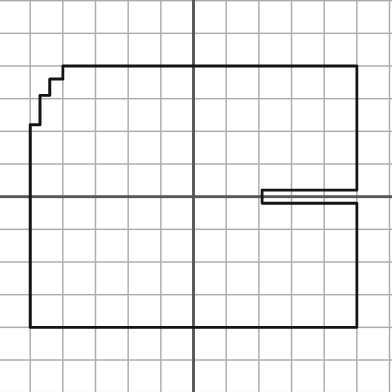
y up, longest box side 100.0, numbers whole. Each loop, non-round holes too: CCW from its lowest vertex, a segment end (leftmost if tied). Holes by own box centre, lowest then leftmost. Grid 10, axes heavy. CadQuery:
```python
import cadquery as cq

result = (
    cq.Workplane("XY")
    .moveTo(-50.0, -40.0)
    .lineTo(50.0, -40.0)
    .lineTo(50.0, -2.0)
    .lineTo(21.0, -2.0)
    .lineTo(21.0, 2.0)
    .lineTo(50.0, 2.0)
    .lineTo(50.0, 40.0)
    .lineTo(-40.0, 40.0)
    .lineTo(-40.0, 36.0)
    .lineTo(-44.0, 36.0)
    .lineTo(-44.0, 31.0)
    .lineTo(-47.0, 31.0)
    .lineTo(-47.0, 22.0)
    .lineTo(-50.0, 22.0)
    .close()
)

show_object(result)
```